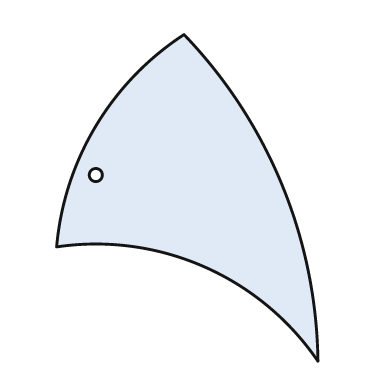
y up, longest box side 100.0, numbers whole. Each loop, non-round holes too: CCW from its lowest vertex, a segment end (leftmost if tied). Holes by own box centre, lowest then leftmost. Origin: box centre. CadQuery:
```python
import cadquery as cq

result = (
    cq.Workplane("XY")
    .moveTo(40.0, -50.0)
    .threePointArc((29.0, 4.0), (-1.0, 50.0))
    .threePointArc((-28.0, 22.0), (-40.0, -15.0))
    .threePointArc((5.0, -21.0), (40.0, -50.0))
    .close()
    .moveTo(-28.0, 7.0)
    .circle(2.0)
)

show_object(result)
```